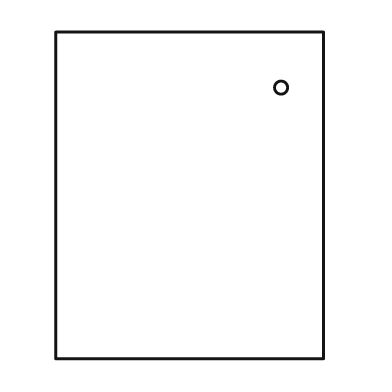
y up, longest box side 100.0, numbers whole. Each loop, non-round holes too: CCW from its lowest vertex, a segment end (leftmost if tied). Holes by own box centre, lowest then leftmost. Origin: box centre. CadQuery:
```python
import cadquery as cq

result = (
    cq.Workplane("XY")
    .moveTo(-41.0, -50.0)
    .lineTo(41.0, -50.0)
    .lineTo(41.0, 50.0)
    .lineTo(-41.0, 50.0)
    .close()
    .moveTo(28.0, 33.0)
    .circle(2.0)
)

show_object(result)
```